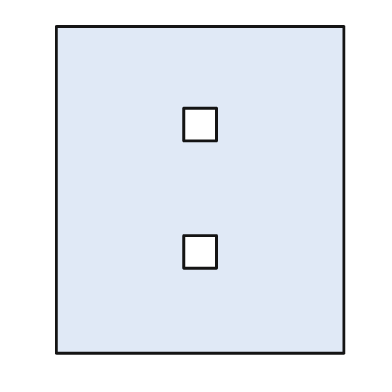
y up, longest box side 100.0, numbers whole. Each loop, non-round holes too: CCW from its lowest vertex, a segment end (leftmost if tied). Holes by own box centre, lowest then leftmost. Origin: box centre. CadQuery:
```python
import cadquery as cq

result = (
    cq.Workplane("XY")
    .moveTo(-44.0, -50.0)
    .lineTo(44.0, -50.0)
    .lineTo(44.0, 50.0)
    .lineTo(-44.0, 50.0)
    .close()
    .moveTo(-5.0, -24.0)
    .lineTo(5.0, -24.0)
    .lineTo(5.0, -14.0)
    .lineTo(-5.0, -14.0)
    .close()
    .moveTo(-5.0, 15.0)
    .lineTo(5.0, 15.0)
    .lineTo(5.0, 25.0)
    .lineTo(-5.0, 25.0)
    .close()
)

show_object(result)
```